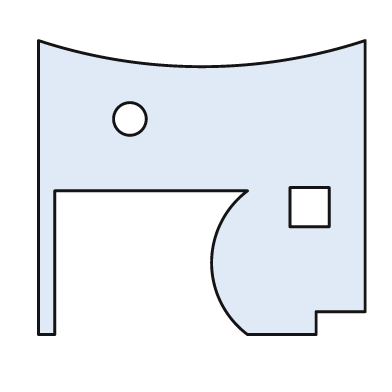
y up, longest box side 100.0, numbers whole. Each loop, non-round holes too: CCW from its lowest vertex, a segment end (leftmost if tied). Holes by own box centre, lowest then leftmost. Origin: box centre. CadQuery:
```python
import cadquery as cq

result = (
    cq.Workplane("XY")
    .moveTo(-50.0, -45.0)
    .lineTo(-45.0, -45.0)
    .lineTo(-45.0, -1.0)
    .lineTo(14.0, -1.0)
    .threePointArc((3.0, -23.0), (14.0, -45.0))
    .lineTo(35.0, -45.0)
    .lineTo(35.0, -38.0)
    .lineTo(50.0, -38.0)
    .lineTo(50.0, 45.0)
    .threePointArc((0.0, 37.0), (-50.0, 45.0))
    .close()
    .moveTo(27.0, -12.0)
    .lineTo(39.0, -12.0)
    .lineTo(39.0, 0.0)
    .lineTo(27.0, 0.0)
    .close()
    .moveTo(-22.0, 21.0)
    .circle(5.0)
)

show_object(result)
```